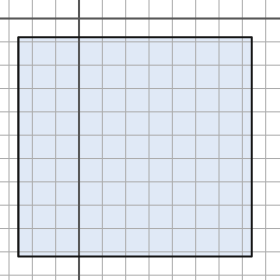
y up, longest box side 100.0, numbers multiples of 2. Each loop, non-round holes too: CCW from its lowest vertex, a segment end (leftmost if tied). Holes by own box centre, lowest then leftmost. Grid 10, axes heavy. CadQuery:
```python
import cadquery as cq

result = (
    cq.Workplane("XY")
    .moveTo(-26.0, -102.0)
    .lineTo(74.0, -102.0)
    .lineTo(74.0, -8.0)
    .lineTo(-26.0, -8.0)
    .close()
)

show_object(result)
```